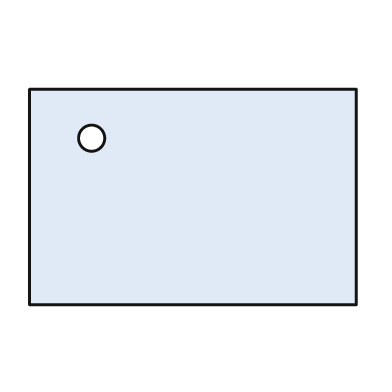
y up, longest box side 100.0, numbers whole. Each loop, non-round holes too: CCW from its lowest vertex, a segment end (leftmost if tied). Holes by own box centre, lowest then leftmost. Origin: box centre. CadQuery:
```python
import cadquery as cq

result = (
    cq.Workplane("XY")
    .moveTo(-50.0, -33.0)
    .lineTo(50.0, -33.0)
    .lineTo(50.0, 33.0)
    .lineTo(-50.0, 33.0)
    .close()
    .moveTo(-31.0, 18.0)
    .circle(4.0)
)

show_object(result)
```